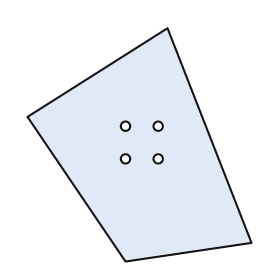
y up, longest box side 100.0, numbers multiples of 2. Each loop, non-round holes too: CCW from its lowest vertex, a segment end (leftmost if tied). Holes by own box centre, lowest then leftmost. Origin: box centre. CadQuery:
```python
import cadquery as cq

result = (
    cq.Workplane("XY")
    .moveTo(-6.0, -50.0)
    .lineTo(48.0, -42.0)
    .lineTo(12.0, 50.0)
    .lineTo(-48.0, 12.0)
    .close()
    .moveTo(-6.0, -6.0)
    .circle(2.0)
    .moveTo(8.0, -6.0)
    .circle(2.0)
    .moveTo(-6.0, 8.0)
    .circle(2.0)
    .moveTo(8.0, 8.0)
    .circle(2.0)
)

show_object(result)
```